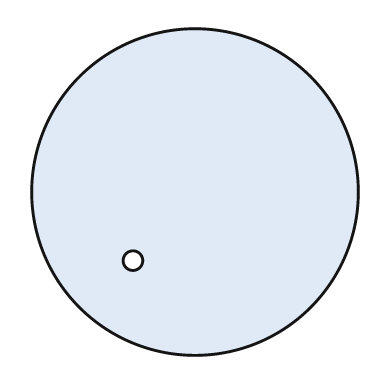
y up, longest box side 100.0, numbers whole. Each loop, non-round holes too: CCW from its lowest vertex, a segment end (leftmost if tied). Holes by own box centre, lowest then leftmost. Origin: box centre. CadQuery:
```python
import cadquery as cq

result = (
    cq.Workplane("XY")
    .moveTo(0.0, 0.0)
    .circle(50.0)
    .moveTo(-19.0, -21.0)
    .circle(3.0)
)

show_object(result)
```